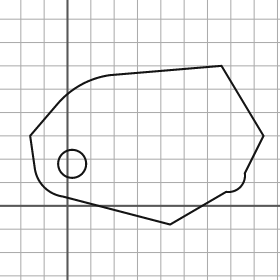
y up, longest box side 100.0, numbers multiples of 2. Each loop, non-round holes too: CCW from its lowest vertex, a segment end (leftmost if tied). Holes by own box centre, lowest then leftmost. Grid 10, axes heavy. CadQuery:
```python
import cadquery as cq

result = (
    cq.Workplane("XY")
    .moveTo(44.0, -8.0)
    .lineTo(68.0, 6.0)
    .threePointArc((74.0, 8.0), (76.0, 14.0))
    .lineTo(84.0, 30.0)
    .lineTo(66.0, 60.0)
    .lineTo(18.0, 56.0)
    .threePointArc((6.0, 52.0), (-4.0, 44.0))
    .lineTo(-16.0, 30.0)
    .lineTo(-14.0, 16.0)
    .threePointArc((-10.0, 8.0), (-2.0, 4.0))
    .close()
    .moveTo(2.0, 18.0)
    .circle(6.0)
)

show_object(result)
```